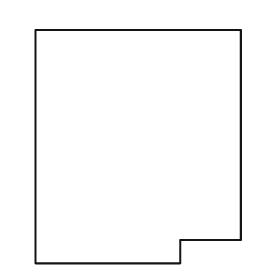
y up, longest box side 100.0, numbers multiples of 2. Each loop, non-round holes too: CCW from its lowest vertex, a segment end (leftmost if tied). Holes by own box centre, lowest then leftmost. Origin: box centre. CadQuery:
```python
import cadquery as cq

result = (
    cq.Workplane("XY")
    .moveTo(-44.0, -50.0)
    .lineTo(18.0, -50.0)
    .lineTo(18.0, -40.0)
    .lineTo(44.0, -40.0)
    .lineTo(44.0, 50.0)
    .lineTo(-44.0, 50.0)
    .close()
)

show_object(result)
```